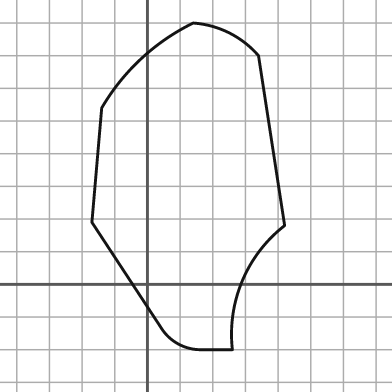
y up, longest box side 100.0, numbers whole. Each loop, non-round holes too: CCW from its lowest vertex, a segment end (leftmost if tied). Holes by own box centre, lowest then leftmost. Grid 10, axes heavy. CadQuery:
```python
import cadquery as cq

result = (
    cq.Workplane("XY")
    .moveTo(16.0, -20.0)
    .lineTo(26.0, -20.0)
    .threePointArc((29.0, 1.0), (42.0, 18.0))
    .lineTo(34.0, 70.0)
    .threePointArc((25.0, 77.0), (14.0, 80.0))
    .threePointArc((-2.0, 69.0), (-14.0, 54.0))
    .lineTo(-17.0, 19.0)
    .lineTo(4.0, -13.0)
    .threePointArc((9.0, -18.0), (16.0, -20.0))
    .close()
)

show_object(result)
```